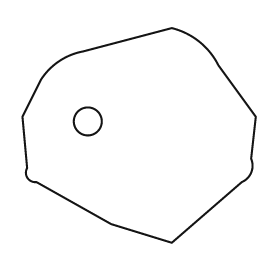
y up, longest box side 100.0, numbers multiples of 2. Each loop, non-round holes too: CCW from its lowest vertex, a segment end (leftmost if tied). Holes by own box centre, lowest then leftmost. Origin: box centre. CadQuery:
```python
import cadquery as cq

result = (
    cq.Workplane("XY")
    .moveTo(14.0, -46.0)
    .lineTo(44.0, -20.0)
    .threePointArc((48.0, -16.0), (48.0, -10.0))
    .lineTo(50.0, 8.0)
    .lineTo(34.0, 30.0)
    .threePointArc((26.0, 40.0), (14.0, 46.0))
    .lineTo(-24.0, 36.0)
    .threePointArc((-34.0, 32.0), (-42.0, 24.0))
    .lineTo(-50.0, 8.0)
    .lineTo(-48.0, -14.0)
    .threePointArc((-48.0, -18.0), (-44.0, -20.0))
    .lineTo(-12.0, -38.0)
    .close()
    .moveTo(-22.0, 6.0)
    .circle(6.0)
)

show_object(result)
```